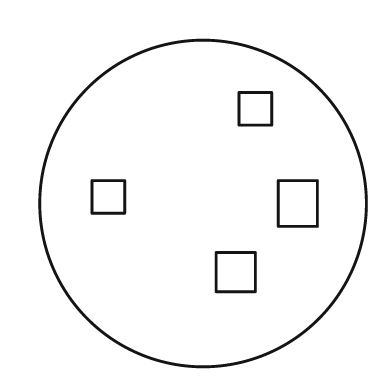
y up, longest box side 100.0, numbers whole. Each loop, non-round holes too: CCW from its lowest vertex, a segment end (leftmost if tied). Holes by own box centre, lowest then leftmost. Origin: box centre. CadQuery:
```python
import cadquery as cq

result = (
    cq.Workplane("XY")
    .moveTo(0.0, 0.0)
    .circle(50.0)
    .moveTo(4.0, -27.0)
    .lineTo(16.0, -27.0)
    .lineTo(16.0, -15.0)
    .lineTo(4.0, -15.0)
    .close()
    .moveTo(23.0, -7.0)
    .lineTo(35.0, -7.0)
    .lineTo(35.0, 7.0)
    .lineTo(23.0, 7.0)
    .close()
    .moveTo(-34.0, -3.0)
    .lineTo(-24.0, -3.0)
    .lineTo(-24.0, 7.0)
    .lineTo(-34.0, 7.0)
    .close()
    .moveTo(11.0, 24.0)
    .lineTo(21.0, 24.0)
    .lineTo(21.0, 34.0)
    .lineTo(11.0, 34.0)
    .close()
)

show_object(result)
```